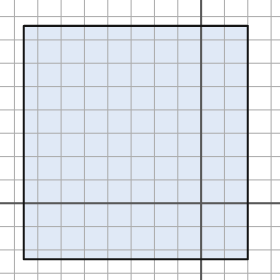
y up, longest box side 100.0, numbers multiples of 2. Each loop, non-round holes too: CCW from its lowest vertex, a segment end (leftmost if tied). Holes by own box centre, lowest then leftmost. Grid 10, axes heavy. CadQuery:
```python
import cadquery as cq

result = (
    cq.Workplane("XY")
    .moveTo(-76.0, -24.0)
    .lineTo(20.0, -24.0)
    .lineTo(20.0, 76.0)
    .lineTo(-76.0, 76.0)
    .close()
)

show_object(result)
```